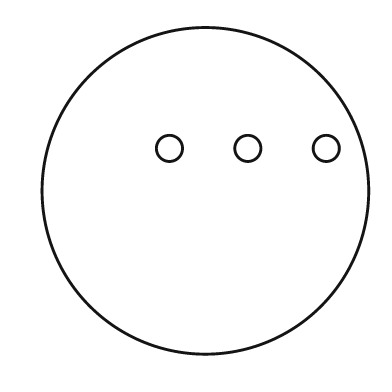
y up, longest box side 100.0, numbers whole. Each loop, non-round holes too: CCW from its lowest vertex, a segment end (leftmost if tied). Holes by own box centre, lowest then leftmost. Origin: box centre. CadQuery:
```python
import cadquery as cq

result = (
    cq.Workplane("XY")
    .moveTo(0.0, 0.0)
    .circle(50.0)
    .moveTo(-11.0, 13.0)
    .circle(4.0)
    .moveTo(13.0, 13.0)
    .circle(4.0)
    .moveTo(37.0, 13.0)
    .circle(4.0)
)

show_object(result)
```